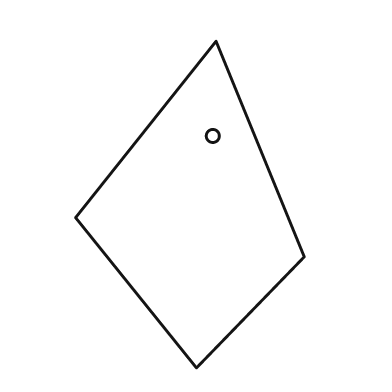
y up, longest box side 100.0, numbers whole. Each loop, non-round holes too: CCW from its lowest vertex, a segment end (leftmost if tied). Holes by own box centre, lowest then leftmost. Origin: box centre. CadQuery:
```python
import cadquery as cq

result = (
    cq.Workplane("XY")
    .moveTo(2.0, -50.0)
    .lineTo(35.0, -16.0)
    .lineTo(8.0, 50.0)
    .lineTo(-35.0, -4.0)
    .close()
    .moveTo(7.0, 21.0)
    .circle(2.0)
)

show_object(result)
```